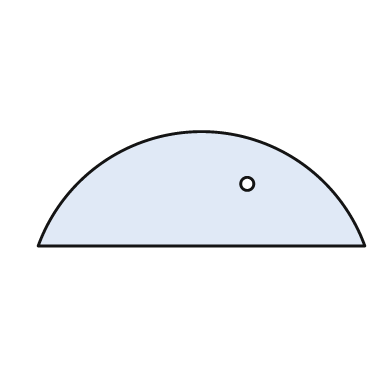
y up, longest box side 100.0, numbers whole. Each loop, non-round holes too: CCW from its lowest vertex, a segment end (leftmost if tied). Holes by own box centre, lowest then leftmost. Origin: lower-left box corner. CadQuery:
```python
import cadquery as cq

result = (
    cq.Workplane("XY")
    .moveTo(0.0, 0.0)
    .lineTo(100.0, 0.0)
    .threePointArc((50.0, 35.0), (0.0, 0.0))
    .close()
    .moveTo(64.0, 19.0)
    .circle(2.0)
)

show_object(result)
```